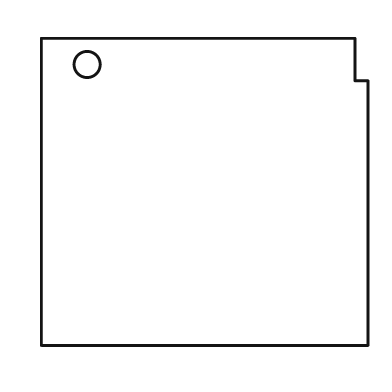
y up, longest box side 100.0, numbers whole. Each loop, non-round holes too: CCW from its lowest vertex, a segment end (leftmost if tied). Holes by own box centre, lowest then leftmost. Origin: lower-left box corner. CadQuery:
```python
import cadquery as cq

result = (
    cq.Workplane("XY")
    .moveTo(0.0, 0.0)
    .lineTo(100.0, 0.0)
    .lineTo(100.0, 81.0)
    .lineTo(96.0, 81.0)
    .lineTo(96.0, 94.0)
    .lineTo(0.0, 94.0)
    .close()
    .moveTo(14.0, 86.0)
    .circle(4.0)
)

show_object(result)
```